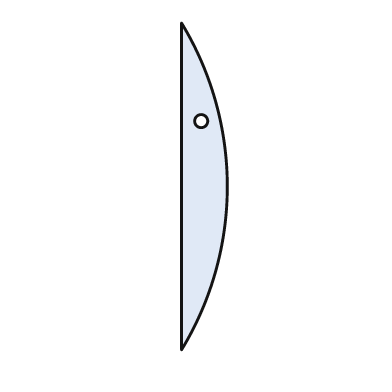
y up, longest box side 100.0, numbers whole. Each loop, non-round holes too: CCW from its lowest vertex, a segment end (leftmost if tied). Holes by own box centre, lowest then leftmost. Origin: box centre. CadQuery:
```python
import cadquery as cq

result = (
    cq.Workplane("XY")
    .moveTo(-7.0, -50.0)
    .threePointArc((7.0, 0.0), (-7.0, 50.0))
    .close()
    .moveTo(-1.0, 20.0)
    .circle(2.0)
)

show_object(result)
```